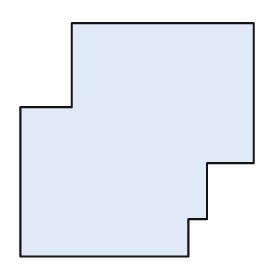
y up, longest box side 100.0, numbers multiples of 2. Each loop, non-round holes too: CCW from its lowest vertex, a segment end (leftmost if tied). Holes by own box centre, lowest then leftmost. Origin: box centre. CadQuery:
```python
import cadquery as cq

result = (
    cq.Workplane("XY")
    .moveTo(-50.0, -50.0)
    .lineTo(22.0, -50.0)
    .lineTo(22.0, -34.0)
    .lineTo(30.0, -34.0)
    .lineTo(30.0, -10.0)
    .lineTo(50.0, -10.0)
    .lineTo(50.0, 50.0)
    .lineTo(-28.0, 50.0)
    .lineTo(-28.0, 14.0)
    .lineTo(-50.0, 14.0)
    .close()
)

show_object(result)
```